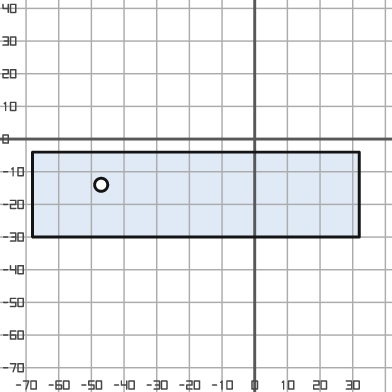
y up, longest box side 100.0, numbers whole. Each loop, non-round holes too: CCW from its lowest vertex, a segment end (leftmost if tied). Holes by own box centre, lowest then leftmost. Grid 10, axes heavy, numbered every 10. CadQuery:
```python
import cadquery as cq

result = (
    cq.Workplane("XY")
    .moveTo(-68.0, -30.0)
    .lineTo(32.0, -30.0)
    .lineTo(32.0, -4.0)
    .lineTo(-68.0, -4.0)
    .close()
    .moveTo(-47.0, -14.0)
    .circle(2.0)
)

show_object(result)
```